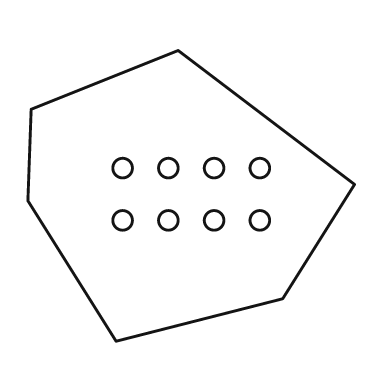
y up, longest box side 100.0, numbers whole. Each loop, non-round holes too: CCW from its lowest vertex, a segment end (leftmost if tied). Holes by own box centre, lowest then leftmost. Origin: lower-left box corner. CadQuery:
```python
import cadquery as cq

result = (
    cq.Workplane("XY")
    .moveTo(27.0, 0.0)
    .lineTo(78.0, 13.0)
    .lineTo(100.0, 48.0)
    .lineTo(46.0, 89.0)
    .lineTo(1.0, 71.0)
    .lineTo(0.0, 43.0)
    .close()
    .moveTo(29.0, 37.0)
    .circle(3.0)
    .moveTo(43.0, 37.0)
    .circle(3.0)
    .moveTo(57.0, 37.0)
    .circle(3.0)
    .moveTo(71.0, 37.0)
    .circle(3.0)
    .moveTo(29.0, 53.0)
    .circle(3.0)
    .moveTo(43.0, 53.0)
    .circle(3.0)
    .moveTo(57.0, 53.0)
    .circle(3.0)
    .moveTo(71.0, 53.0)
    .circle(3.0)
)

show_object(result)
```